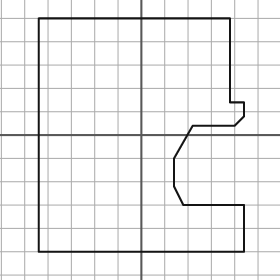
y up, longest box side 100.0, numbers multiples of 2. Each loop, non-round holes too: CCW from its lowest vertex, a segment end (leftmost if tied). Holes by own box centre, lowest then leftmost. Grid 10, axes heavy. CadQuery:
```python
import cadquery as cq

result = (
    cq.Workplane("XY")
    .moveTo(-44.0, -50.0)
    .lineTo(44.0, -50.0)
    .lineTo(44.0, -30.0)
    .lineTo(18.0, -30.0)
    .lineTo(14.0, -22.0)
    .lineTo(14.0, -10.0)
    .lineTo(22.0, 4.0)
    .lineTo(40.0, 4.0)
    .lineTo(44.0, 8.0)
    .lineTo(44.0, 14.0)
    .lineTo(38.0, 14.0)
    .lineTo(38.0, 50.0)
    .lineTo(-44.0, 50.0)
    .close()
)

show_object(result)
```